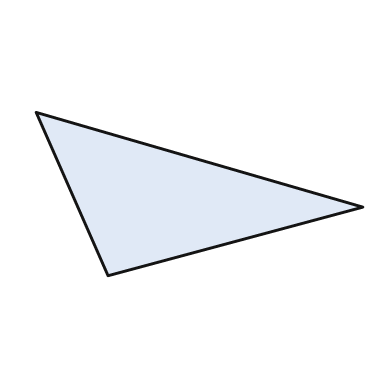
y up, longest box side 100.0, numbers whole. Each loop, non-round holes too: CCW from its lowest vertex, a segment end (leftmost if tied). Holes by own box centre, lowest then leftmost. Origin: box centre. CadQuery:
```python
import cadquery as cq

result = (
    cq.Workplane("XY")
    .moveTo(-28.0, -25.0)
    .lineTo(50.0, -4.0)
    .lineTo(-50.0, 25.0)
    .close()
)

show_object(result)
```